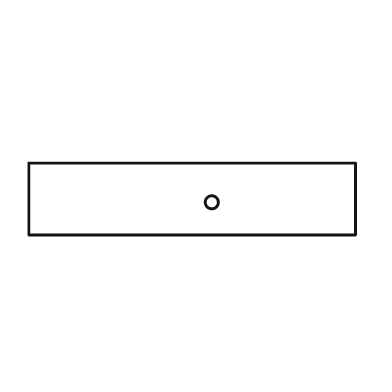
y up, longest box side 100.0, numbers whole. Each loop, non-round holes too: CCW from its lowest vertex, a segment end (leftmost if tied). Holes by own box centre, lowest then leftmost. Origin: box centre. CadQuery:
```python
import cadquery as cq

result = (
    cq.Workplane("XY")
    .moveTo(-50.0, -11.0)
    .lineTo(50.0, -11.0)
    .lineTo(50.0, 11.0)
    .lineTo(-50.0, 11.0)
    .close()
    .moveTo(6.0, -1.0)
    .circle(2.0)
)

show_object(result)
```